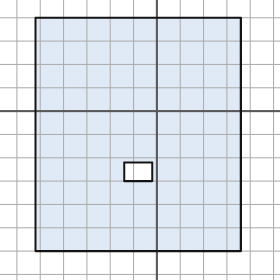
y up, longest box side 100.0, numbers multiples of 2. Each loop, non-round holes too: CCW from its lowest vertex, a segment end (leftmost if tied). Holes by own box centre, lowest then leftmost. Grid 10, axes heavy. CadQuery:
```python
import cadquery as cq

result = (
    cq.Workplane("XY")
    .moveTo(-52.0, -60.0)
    .lineTo(36.0, -60.0)
    .lineTo(36.0, 40.0)
    .lineTo(-52.0, 40.0)
    .close()
    .moveTo(-14.0, -30.0)
    .lineTo(-2.0, -30.0)
    .lineTo(-2.0, -22.0)
    .lineTo(-14.0, -22.0)
    .close()
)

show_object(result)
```